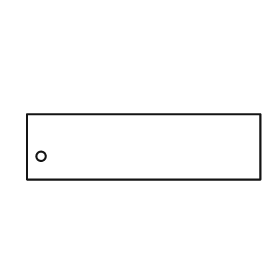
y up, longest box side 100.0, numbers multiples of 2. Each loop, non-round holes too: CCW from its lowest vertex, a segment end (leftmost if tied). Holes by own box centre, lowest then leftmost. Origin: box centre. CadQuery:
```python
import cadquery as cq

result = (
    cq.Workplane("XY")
    .moveTo(-50.0, -14.0)
    .lineTo(50.0, -14.0)
    .lineTo(50.0, 14.0)
    .lineTo(-50.0, 14.0)
    .close()
    .moveTo(-44.0, -4.0)
    .circle(2.0)
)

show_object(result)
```